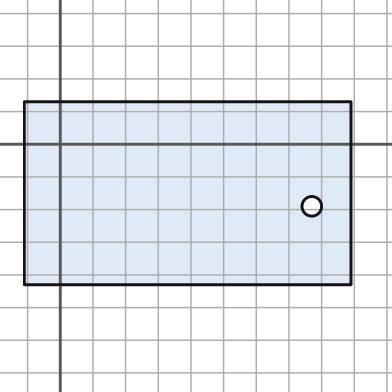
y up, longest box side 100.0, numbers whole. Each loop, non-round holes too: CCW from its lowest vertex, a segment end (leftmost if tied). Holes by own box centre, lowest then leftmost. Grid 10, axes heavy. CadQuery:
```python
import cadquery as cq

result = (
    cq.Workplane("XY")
    .moveTo(-11.0, -43.0)
    .lineTo(89.0, -43.0)
    .lineTo(89.0, 13.0)
    .lineTo(-11.0, 13.0)
    .close()
    .moveTo(77.0, -19.0)
    .circle(3.0)
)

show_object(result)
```